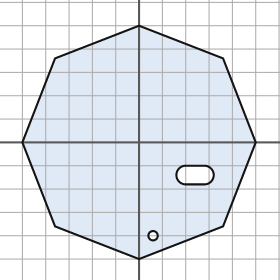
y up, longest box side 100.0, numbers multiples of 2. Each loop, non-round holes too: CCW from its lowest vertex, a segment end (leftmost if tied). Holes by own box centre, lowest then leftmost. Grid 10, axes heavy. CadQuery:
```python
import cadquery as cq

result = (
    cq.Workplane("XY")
    .moveTo(0.0, -50.0)
    .lineTo(36.0, -36.0)
    .lineTo(50.0, 0.0)
    .lineTo(36.0, 36.0)
    .lineTo(0.0, 50.0)
    .lineTo(-36.0, 36.0)
    .lineTo(-50.0, 0.0)
    .lineTo(-36.0, -36.0)
    .close()
    .moveTo(6.0, -40.0)
    .circle(2.0)
    .moveTo(20.0, -18.0)
    .lineTo(28.0, -18.0)
    .threePointArc((32.0, -14.0), (28.0, -10.0))
    .lineTo(20.0, -10.0)
    .threePointArc((16.0, -14.0), (20.0, -18.0))
    .close()
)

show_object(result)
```